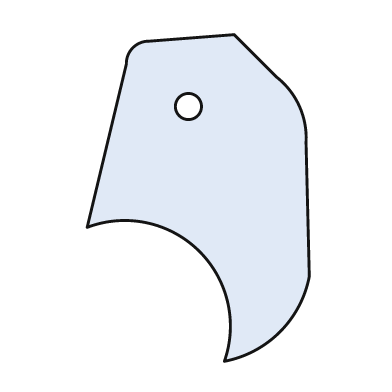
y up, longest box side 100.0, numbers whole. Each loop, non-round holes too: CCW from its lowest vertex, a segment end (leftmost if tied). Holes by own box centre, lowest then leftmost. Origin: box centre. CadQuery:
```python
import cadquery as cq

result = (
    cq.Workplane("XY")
    .moveTo(8.0, -50.0)
    .threePointArc((25.0, -41.0), (34.0, -24.0))
    .lineTo(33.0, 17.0)
    .threePointArc((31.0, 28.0), (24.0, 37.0))
    .lineTo(11.0, 50.0)
    .lineTo(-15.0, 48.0)
    .threePointArc((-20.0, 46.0), (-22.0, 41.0))
    .lineTo(-34.0, -9.0)
    .threePointArc((0.0, -16.0), (8.0, -50.0))
    .close()
    .moveTo(-3.0, 28.0)
    .circle(4.0)
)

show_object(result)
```